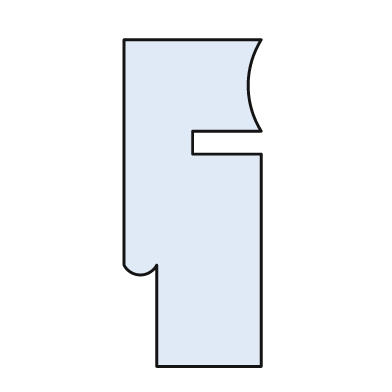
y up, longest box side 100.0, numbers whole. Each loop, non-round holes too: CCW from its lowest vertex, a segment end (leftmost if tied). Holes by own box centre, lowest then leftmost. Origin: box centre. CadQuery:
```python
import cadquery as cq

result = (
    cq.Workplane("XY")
    .moveTo(-11.0, -50.0)
    .lineTo(21.0, -50.0)
    .lineTo(21.0, 15.0)
    .lineTo(0.0, 15.0)
    .lineTo(0.0, 22.0)
    .lineTo(21.0, 22.0)
    .threePointArc((17.0, 36.0), (21.0, 50.0))
    .lineTo(-21.0, 50.0)
    .lineTo(-21.0, -19.0)
    .threePointArc((-16.0, -22.0), (-11.0, -19.0))
    .close()
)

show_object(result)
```